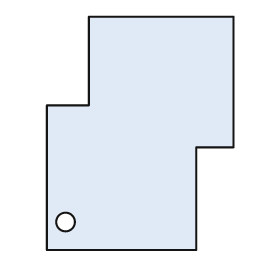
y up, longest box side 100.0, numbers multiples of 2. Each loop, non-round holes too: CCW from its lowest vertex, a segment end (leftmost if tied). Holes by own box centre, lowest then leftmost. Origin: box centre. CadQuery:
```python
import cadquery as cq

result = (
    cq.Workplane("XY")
    .moveTo(-40.0, -50.0)
    .lineTo(24.0, -50.0)
    .lineTo(24.0, -6.0)
    .lineTo(40.0, -6.0)
    .lineTo(40.0, 50.0)
    .lineTo(-22.0, 50.0)
    .lineTo(-22.0, 12.0)
    .lineTo(-40.0, 12.0)
    .close()
    .moveTo(-32.0, -38.0)
    .circle(4.0)
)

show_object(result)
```